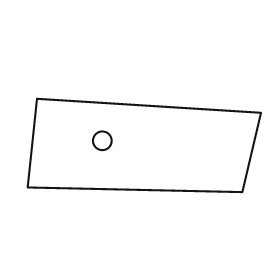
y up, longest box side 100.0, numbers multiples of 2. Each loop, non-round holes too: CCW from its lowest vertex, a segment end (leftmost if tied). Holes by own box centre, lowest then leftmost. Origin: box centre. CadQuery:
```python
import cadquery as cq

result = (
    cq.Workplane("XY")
    .moveTo(42.0, -20.0)
    .lineTo(50.0, 14.0)
    .lineTo(-46.0, 20.0)
    .lineTo(-50.0, -18.0)
    .close()
    .moveTo(-18.0, 2.0)
    .circle(4.0)
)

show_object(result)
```